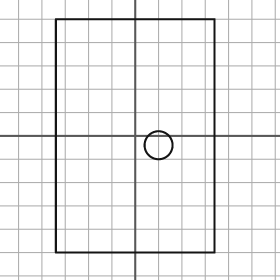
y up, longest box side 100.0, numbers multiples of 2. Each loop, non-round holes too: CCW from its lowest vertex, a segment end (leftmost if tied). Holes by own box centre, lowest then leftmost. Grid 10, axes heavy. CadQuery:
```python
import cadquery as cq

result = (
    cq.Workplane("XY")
    .moveTo(-34.0, -50.0)
    .lineTo(34.0, -50.0)
    .lineTo(34.0, 50.0)
    .lineTo(-34.0, 50.0)
    .close()
    .moveTo(10.0, -4.0)
    .circle(6.0)
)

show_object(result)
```